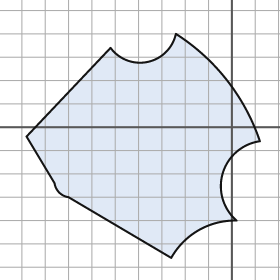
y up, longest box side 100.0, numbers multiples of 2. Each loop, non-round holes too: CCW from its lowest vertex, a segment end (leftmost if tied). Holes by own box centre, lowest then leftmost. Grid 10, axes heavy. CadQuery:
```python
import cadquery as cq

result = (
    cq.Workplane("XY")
    .moveTo(-26.0, -56.0)
    .threePointArc((-14.0, -44.0), (2.0, -40.0))
    .threePointArc((-4.0, -20.0), (12.0, -6.0))
    .threePointArc((-2.0, 20.0), (-24.0, 40.0))
    .threePointArc((-36.0, 28.0), (-52.0, 34.0))
    .lineTo(-88.0, -4.0)
    .lineTo(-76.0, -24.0)
    .threePointArc((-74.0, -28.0), (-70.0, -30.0))
    .close()
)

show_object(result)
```